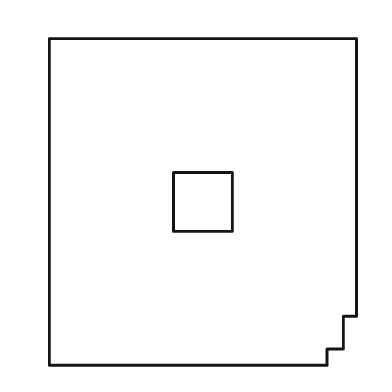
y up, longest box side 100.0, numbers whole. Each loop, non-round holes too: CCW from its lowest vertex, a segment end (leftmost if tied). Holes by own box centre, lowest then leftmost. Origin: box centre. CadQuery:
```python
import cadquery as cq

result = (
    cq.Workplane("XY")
    .moveTo(-47.0, -50.0)
    .lineTo(38.0, -50.0)
    .lineTo(38.0, -45.0)
    .lineTo(43.0, -45.0)
    .lineTo(43.0, -35.0)
    .lineTo(47.0, -35.0)
    .lineTo(47.0, 50.0)
    .lineTo(-47.0, 50.0)
    .close()
    .moveTo(-9.0, -9.0)
    .lineTo(9.0, -9.0)
    .lineTo(9.0, 9.0)
    .lineTo(-9.0, 9.0)
    .close()
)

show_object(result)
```